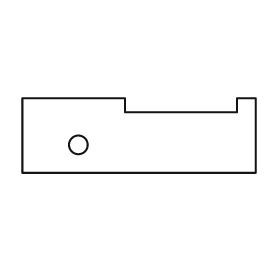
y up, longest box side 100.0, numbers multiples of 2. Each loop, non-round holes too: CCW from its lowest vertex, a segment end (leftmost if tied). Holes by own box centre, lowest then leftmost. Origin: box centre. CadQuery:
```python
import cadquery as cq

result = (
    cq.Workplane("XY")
    .moveTo(-50.0, -16.0)
    .lineTo(50.0, -16.0)
    .lineTo(50.0, 16.0)
    .lineTo(42.0, 16.0)
    .lineTo(42.0, 10.0)
    .lineTo(-6.0, 10.0)
    .lineTo(-6.0, 16.0)
    .lineTo(-50.0, 16.0)
    .close()
    .moveTo(-26.0, -4.0)
    .circle(4.0)
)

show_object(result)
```